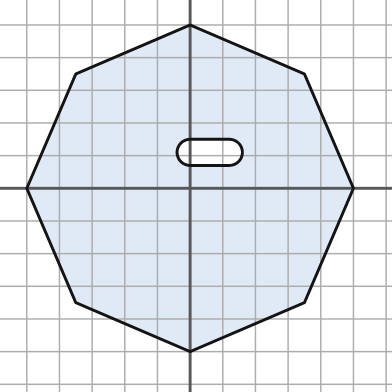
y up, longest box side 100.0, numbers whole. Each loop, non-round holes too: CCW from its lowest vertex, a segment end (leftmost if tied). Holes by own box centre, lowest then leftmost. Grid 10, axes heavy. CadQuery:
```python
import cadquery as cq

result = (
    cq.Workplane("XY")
    .moveTo(0.0, -50.0)
    .lineTo(35.0, -35.0)
    .lineTo(50.0, 0.0)
    .lineTo(35.0, 35.0)
    .lineTo(0.0, 50.0)
    .lineTo(-35.0, 35.0)
    .lineTo(-50.0, 0.0)
    .lineTo(-35.0, -35.0)
    .close()
    .moveTo(0.0, 7.0)
    .lineTo(12.0, 7.0)
    .threePointArc((16.0, 11.0), (12.0, 15.0))
    .lineTo(0.0, 15.0)
    .threePointArc((-4.0, 11.0), (0.0, 7.0))
    .close()
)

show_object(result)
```